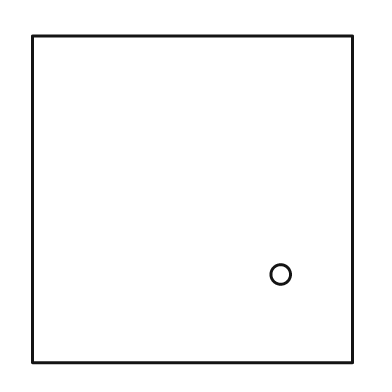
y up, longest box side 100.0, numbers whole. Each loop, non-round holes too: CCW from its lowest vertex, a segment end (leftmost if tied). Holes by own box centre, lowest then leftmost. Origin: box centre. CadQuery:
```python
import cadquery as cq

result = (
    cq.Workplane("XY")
    .moveTo(-49.0, -50.0)
    .lineTo(49.0, -50.0)
    .lineTo(49.0, 50.0)
    .lineTo(-49.0, 50.0)
    .close()
    .moveTo(27.0, -23.0)
    .circle(3.0)
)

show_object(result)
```